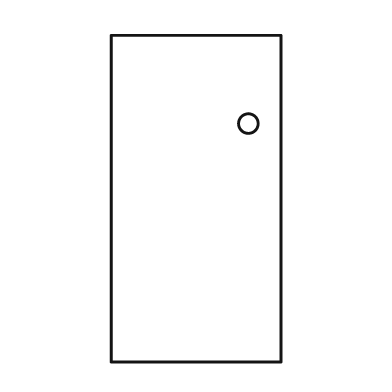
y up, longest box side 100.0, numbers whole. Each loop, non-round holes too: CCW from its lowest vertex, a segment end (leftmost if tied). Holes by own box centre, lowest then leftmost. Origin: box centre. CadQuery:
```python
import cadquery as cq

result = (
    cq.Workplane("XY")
    .moveTo(-26.0, -50.0)
    .lineTo(26.0, -50.0)
    .lineTo(26.0, 50.0)
    .lineTo(-26.0, 50.0)
    .close()
    .moveTo(16.0, 23.0)
    .circle(3.0)
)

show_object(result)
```